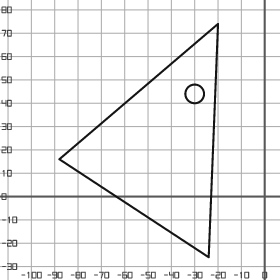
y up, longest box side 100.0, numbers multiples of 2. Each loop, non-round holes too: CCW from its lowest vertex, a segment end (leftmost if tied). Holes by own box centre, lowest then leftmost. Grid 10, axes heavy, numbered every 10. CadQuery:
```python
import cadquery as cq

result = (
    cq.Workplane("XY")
    .moveTo(-24.0, -26.0)
    .lineTo(-20.0, 74.0)
    .lineTo(-88.0, 16.0)
    .close()
    .moveTo(-30.0, 44.0)
    .circle(4.0)
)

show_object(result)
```